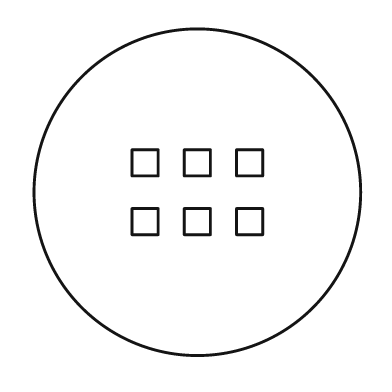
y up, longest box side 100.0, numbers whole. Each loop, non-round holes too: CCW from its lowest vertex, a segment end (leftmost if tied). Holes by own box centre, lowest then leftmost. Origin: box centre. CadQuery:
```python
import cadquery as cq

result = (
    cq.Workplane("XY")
    .moveTo(0.0, 0.0)
    .circle(50.0)
    .moveTo(-20.0, -13.0)
    .lineTo(-12.0, -13.0)
    .lineTo(-12.0, -5.0)
    .lineTo(-20.0, -5.0)
    .close()
    .moveTo(-4.0, -13.0)
    .lineTo(4.0, -13.0)
    .lineTo(4.0, -5.0)
    .lineTo(-4.0, -5.0)
    .close()
    .moveTo(12.0, -13.0)
    .lineTo(20.0, -13.0)
    .lineTo(20.0, -5.0)
    .lineTo(12.0, -5.0)
    .close()
    .moveTo(-20.0, 5.0)
    .lineTo(-12.0, 5.0)
    .lineTo(-12.0, 13.0)
    .lineTo(-20.0, 13.0)
    .close()
    .moveTo(-4.0, 5.0)
    .lineTo(4.0, 5.0)
    .lineTo(4.0, 13.0)
    .lineTo(-4.0, 13.0)
    .close()
    .moveTo(12.0, 5.0)
    .lineTo(20.0, 5.0)
    .lineTo(20.0, 13.0)
    .lineTo(12.0, 13.0)
    .close()
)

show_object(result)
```